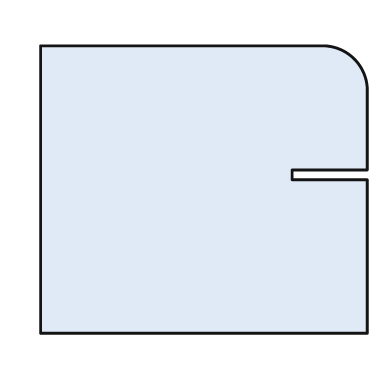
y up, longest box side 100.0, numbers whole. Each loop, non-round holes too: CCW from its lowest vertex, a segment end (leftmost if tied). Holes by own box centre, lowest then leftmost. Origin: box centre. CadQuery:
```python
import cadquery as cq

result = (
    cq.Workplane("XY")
    .moveTo(-50.0, -44.0)
    .lineTo(50.0, -44.0)
    .lineTo(50.0, 3.0)
    .lineTo(27.0, 3.0)
    .lineTo(27.0, 6.0)
    .lineTo(50.0, 6.0)
    .lineTo(50.0, 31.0)
    .threePointArc((46.0, 40.0), (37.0, 44.0))
    .lineTo(-50.0, 44.0)
    .close()
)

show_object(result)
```